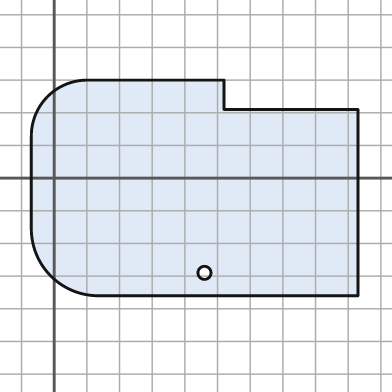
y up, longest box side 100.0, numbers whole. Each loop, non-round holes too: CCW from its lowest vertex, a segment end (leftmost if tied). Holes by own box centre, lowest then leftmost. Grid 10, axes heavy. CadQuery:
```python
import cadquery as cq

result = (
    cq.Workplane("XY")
    .moveTo(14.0, -36.0)
    .lineTo(93.0, -36.0)
    .lineTo(93.0, 21.0)
    .lineTo(52.0, 21.0)
    .lineTo(52.0, 30.0)
    .lineTo(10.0, 30.0)
    .threePointArc((-2.0, 25.0), (-7.0, 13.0))
    .lineTo(-7.0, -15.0)
    .threePointArc((-1.0, -30.0), (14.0, -36.0))
    .close()
    .moveTo(46.0, -29.0)
    .circle(2.0)
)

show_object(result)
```